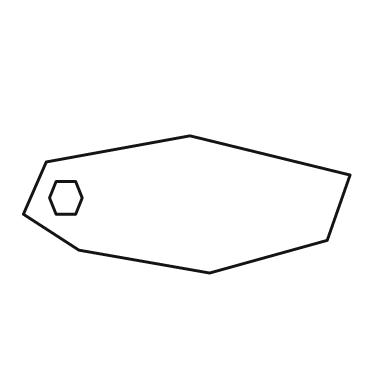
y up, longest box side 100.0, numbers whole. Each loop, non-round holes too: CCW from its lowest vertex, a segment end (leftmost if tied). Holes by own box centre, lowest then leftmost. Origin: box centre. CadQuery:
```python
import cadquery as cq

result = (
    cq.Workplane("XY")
    .moveTo(7.0, -21.0)
    .lineTo(43.0, -11.0)
    .lineTo(50.0, 9.0)
    .lineTo(1.0, 21.0)
    .lineTo(-43.0, 13.0)
    .lineTo(-50.0, -3.0)
    .lineTo(-33.0, -14.0)
    .close()
    .moveTo(-40.0, -3.0)
    .lineTo(-34.0, -3.0)
    .lineTo(-32.0, 2.0)
    .lineTo(-34.0, 7.0)
    .lineTo(-40.0, 7.0)
    .lineTo(-42.0, 2.0)
    .close()
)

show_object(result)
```